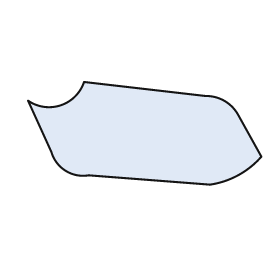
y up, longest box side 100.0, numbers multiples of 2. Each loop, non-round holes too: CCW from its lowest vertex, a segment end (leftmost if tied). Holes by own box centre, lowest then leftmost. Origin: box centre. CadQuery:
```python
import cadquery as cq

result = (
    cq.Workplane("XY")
    .moveTo(28.0, -22.0)
    .threePointArc((40.0, -18.0), (50.0, -10.0))
    .lineTo(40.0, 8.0)
    .threePointArc((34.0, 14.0), (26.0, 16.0))
    .lineTo(-26.0, 22.0)
    .threePointArc((-36.0, 12.0), (-50.0, 14.0))
    .lineTo(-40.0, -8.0)
    .threePointArc((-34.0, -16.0), (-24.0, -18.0))
    .close()
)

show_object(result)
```